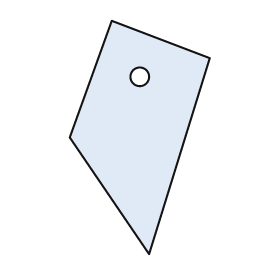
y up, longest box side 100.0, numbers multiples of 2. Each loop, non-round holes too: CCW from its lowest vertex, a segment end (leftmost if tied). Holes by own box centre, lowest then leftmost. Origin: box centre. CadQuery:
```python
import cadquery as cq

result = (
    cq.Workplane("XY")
    .moveTo(4.0, -50.0)
    .lineTo(30.0, 34.0)
    .lineTo(-12.0, 50.0)
    .lineTo(-30.0, 0.0)
    .close()
    .moveTo(0.0, 26.0)
    .circle(4.0)
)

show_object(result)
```